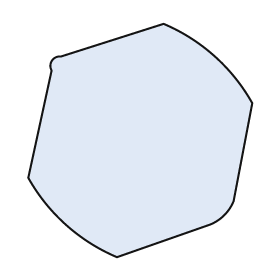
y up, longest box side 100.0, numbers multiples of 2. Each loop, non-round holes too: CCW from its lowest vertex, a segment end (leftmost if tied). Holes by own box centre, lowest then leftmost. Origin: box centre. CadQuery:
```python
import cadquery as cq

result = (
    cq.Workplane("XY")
    .moveTo(-10.0, -50.0)
    .lineTo(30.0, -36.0)
    .threePointArc((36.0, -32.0), (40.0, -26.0))
    .lineTo(48.0, 16.0)
    .threePointArc((32.0, 36.0), (10.0, 50.0))
    .lineTo(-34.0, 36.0)
    .threePointArc((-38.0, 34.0), (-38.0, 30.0))
    .lineTo(-48.0, -16.0)
    .threePointArc((-32.0, -36.0), (-10.0, -50.0))
    .close()
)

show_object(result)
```